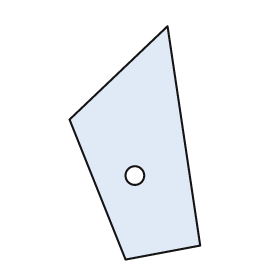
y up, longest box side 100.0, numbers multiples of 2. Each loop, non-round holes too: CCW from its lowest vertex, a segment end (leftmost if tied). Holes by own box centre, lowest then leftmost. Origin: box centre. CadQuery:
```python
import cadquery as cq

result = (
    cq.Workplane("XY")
    .moveTo(-4.0, -50.0)
    .lineTo(28.0, -44.0)
    .lineTo(14.0, 50.0)
    .lineTo(-28.0, 10.0)
    .close()
    .moveTo(0.0, -14.0)
    .circle(4.0)
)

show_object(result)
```